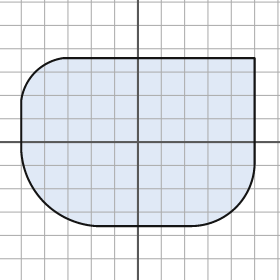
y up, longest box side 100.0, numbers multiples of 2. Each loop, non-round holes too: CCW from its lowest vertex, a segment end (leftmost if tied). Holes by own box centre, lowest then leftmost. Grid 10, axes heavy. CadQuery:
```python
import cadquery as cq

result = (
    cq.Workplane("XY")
    .moveTo(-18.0, -36.0)
    .lineTo(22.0, -36.0)
    .threePointArc((42.0, -28.0), (50.0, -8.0))
    .lineTo(50.0, 36.0)
    .lineTo(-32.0, 36.0)
    .threePointArc((-44.0, 30.0), (-50.0, 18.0))
    .lineTo(-50.0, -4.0)
    .threePointArc((-40.0, -26.0), (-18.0, -36.0))
    .close()
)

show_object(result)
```